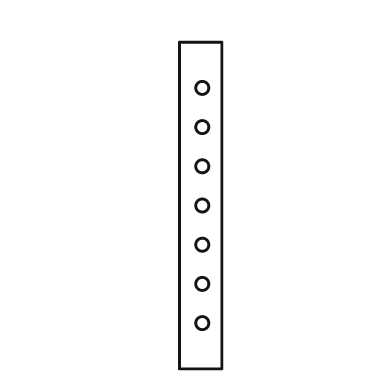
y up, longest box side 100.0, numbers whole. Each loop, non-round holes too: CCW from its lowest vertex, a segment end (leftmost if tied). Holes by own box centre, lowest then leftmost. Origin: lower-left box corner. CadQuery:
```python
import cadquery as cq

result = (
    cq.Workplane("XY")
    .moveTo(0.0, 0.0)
    .lineTo(13.0, 0.0)
    .lineTo(13.0, 100.0)
    .lineTo(0.0, 100.0)
    .close()
    .moveTo(7.0, 14.0)
    .circle(2.0)
    .moveTo(7.0, 26.0)
    .circle(2.0)
    .moveTo(7.0, 38.0)
    .circle(2.0)
    .moveTo(7.0, 50.0)
    .circle(2.0)
    .moveTo(7.0, 62.0)
    .circle(2.0)
    .moveTo(7.0, 74.0)
    .circle(2.0)
    .moveTo(7.0, 86.0)
    .circle(2.0)
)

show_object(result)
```